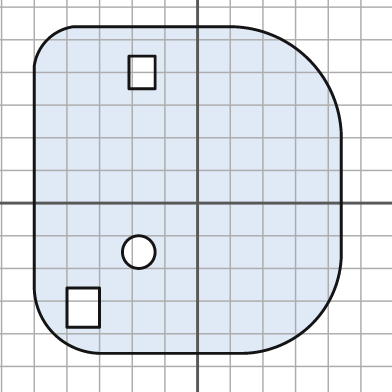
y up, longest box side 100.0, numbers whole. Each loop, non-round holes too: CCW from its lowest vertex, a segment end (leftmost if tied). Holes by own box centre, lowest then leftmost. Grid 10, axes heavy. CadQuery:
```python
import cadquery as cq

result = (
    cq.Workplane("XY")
    .moveTo(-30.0, -46.0)
    .lineTo(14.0, -46.0)
    .threePointArc((35.0, -37.0), (44.0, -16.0))
    .lineTo(44.0, 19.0)
    .threePointArc((34.0, 44.0), (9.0, 54.0))
    .lineTo(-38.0, 54.0)
    .threePointArc((-46.0, 50.0), (-50.0, 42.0))
    .lineTo(-50.0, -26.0)
    .threePointArc((-44.0, -40.0), (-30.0, -46.0))
    .close()
    .moveTo(-40.0, -38.0)
    .lineTo(-30.0, -38.0)
    .lineTo(-30.0, -26.0)
    .lineTo(-40.0, -26.0)
    .close()
    .moveTo(-18.0, -15.0)
    .circle(5.0)
    .moveTo(-21.0, 35.0)
    .lineTo(-13.0, 35.0)
    .lineTo(-13.0, 45.0)
    .lineTo(-21.0, 45.0)
    .close()
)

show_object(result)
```